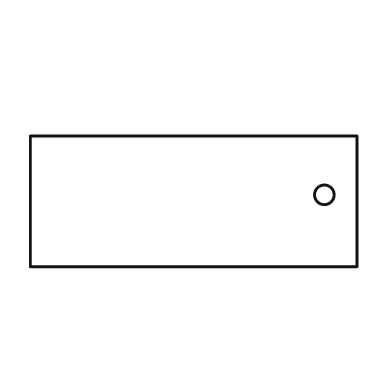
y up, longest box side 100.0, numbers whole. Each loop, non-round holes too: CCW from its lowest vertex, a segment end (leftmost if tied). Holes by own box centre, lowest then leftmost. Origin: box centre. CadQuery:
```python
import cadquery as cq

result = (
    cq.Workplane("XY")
    .moveTo(-50.0, -20.0)
    .lineTo(50.0, -20.0)
    .lineTo(50.0, 20.0)
    .lineTo(-50.0, 20.0)
    .close()
    .moveTo(40.0, 2.0)
    .circle(3.0)
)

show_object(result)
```